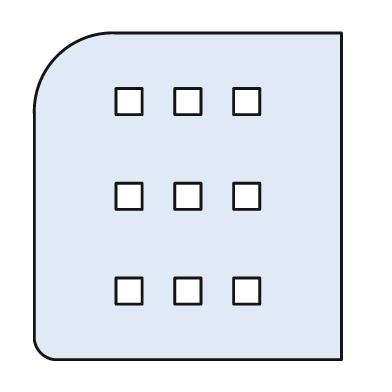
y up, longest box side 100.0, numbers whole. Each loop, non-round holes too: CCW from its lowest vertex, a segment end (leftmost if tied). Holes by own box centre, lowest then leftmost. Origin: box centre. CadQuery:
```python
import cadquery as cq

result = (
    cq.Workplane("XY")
    .moveTo(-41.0, -50.0)
    .lineTo(47.0, -50.0)
    .lineTo(47.0, 50.0)
    .lineTo(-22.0, 50.0)
    .threePointArc((-40.0, 43.0), (-47.0, 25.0))
    .lineTo(-47.0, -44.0)
    .threePointArc((-45.0, -48.0), (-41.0, -50.0))
    .close()
    .moveTo(-22.0, -33.0)
    .lineTo(-14.0, -33.0)
    .lineTo(-14.0, -25.0)
    .lineTo(-22.0, -25.0)
    .close()
    .moveTo(-4.0, -33.0)
    .lineTo(4.0, -33.0)
    .lineTo(4.0, -25.0)
    .lineTo(-4.0, -25.0)
    .close()
    .moveTo(14.0, -33.0)
    .lineTo(22.0, -33.0)
    .lineTo(22.0, -25.0)
    .lineTo(14.0, -25.0)
    .close()
    .moveTo(-22.0, -4.0)
    .lineTo(-14.0, -4.0)
    .lineTo(-14.0, 4.0)
    .lineTo(-22.0, 4.0)
    .close()
    .moveTo(-4.0, -4.0)
    .lineTo(4.0, -4.0)
    .lineTo(4.0, 4.0)
    .lineTo(-4.0, 4.0)
    .close()
    .moveTo(14.0, -4.0)
    .lineTo(22.0, -4.0)
    .lineTo(22.0, 4.0)
    .lineTo(14.0, 4.0)
    .close()
    .moveTo(-22.0, 25.0)
    .lineTo(-14.0, 25.0)
    .lineTo(-14.0, 33.0)
    .lineTo(-22.0, 33.0)
    .close()
    .moveTo(-4.0, 25.0)
    .lineTo(4.0, 25.0)
    .lineTo(4.0, 33.0)
    .lineTo(-4.0, 33.0)
    .close()
    .moveTo(14.0, 25.0)
    .lineTo(22.0, 25.0)
    .lineTo(22.0, 33.0)
    .lineTo(14.0, 33.0)
    .close()
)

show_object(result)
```